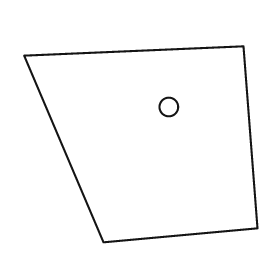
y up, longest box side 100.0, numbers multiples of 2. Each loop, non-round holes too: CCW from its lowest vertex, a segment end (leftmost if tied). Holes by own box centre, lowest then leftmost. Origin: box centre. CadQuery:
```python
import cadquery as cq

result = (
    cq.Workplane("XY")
    .moveTo(-16.0, -42.0)
    .lineTo(50.0, -36.0)
    .lineTo(44.0, 42.0)
    .lineTo(-50.0, 38.0)
    .close()
    .moveTo(12.0, 16.0)
    .circle(4.0)
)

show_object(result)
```